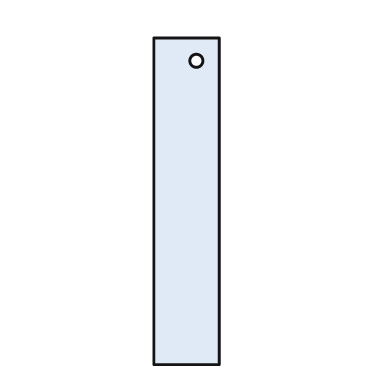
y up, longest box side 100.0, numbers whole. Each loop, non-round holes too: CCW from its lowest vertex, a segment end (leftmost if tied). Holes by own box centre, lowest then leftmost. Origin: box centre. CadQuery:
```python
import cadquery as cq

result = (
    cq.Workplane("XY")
    .moveTo(-10.0, -50.0)
    .lineTo(10.0, -50.0)
    .lineTo(10.0, 50.0)
    .lineTo(-10.0, 50.0)
    .close()
    .moveTo(3.0, 43.0)
    .circle(2.0)
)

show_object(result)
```